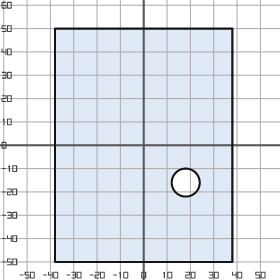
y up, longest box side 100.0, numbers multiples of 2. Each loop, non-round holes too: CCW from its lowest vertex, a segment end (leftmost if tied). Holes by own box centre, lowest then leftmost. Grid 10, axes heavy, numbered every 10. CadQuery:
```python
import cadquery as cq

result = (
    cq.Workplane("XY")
    .moveTo(-38.0, -50.0)
    .lineTo(38.0, -50.0)
    .lineTo(38.0, 50.0)
    .lineTo(-38.0, 50.0)
    .close()
    .moveTo(18.0, -16.0)
    .circle(6.0)
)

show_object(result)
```